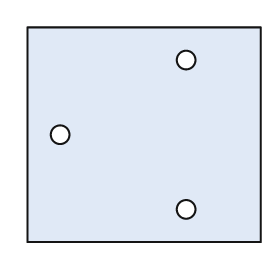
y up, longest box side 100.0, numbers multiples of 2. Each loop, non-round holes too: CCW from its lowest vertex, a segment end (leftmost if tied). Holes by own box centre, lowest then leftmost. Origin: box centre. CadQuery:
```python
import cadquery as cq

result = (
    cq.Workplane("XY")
    .moveTo(-50.0, -46.0)
    .lineTo(50.0, -46.0)
    .lineTo(50.0, 46.0)
    .lineTo(-50.0, 46.0)
    .close()
    .moveTo(18.0, -32.0)
    .circle(4.0)
    .moveTo(-36.0, 0.0)
    .circle(4.0)
    .moveTo(18.0, 32.0)
    .circle(4.0)
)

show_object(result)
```